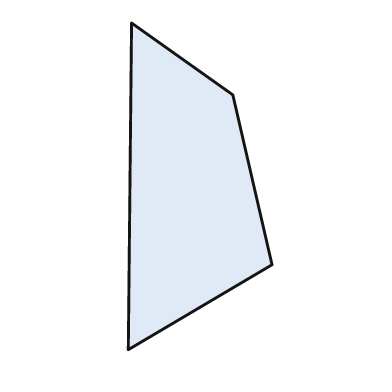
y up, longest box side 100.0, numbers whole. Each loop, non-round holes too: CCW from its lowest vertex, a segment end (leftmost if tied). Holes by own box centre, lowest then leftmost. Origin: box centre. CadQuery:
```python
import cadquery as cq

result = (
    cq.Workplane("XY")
    .moveTo(-22.0, -50.0)
    .lineTo(22.0, -24.0)
    .lineTo(10.0, 28.0)
    .lineTo(-21.0, 50.0)
    .close()
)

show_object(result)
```